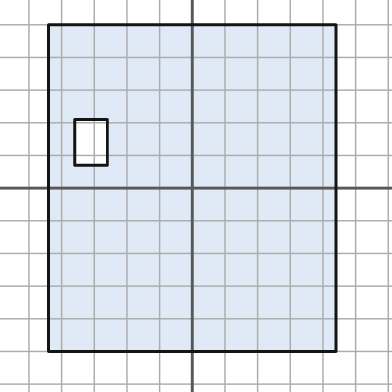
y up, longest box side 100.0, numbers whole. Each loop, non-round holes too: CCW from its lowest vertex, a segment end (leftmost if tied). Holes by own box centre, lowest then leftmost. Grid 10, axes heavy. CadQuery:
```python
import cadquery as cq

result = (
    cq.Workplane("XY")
    .moveTo(-44.0, -50.0)
    .lineTo(44.0, -50.0)
    .lineTo(44.0, 50.0)
    .lineTo(-44.0, 50.0)
    .close()
    .moveTo(-36.0, 7.0)
    .lineTo(-26.0, 7.0)
    .lineTo(-26.0, 21.0)
    .lineTo(-36.0, 21.0)
    .close()
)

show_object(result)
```